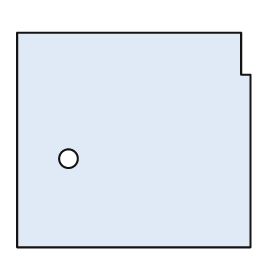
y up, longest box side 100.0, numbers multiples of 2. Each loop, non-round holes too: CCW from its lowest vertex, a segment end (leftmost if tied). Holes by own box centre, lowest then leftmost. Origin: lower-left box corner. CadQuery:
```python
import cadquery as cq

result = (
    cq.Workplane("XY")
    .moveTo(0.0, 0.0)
    .lineTo(100.0, 0.0)
    .lineTo(100.0, 74.0)
    .lineTo(96.0, 74.0)
    .lineTo(96.0, 92.0)
    .lineTo(0.0, 92.0)
    .close()
    .moveTo(22.0, 38.0)
    .circle(4.0)
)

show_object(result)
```